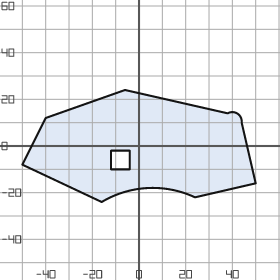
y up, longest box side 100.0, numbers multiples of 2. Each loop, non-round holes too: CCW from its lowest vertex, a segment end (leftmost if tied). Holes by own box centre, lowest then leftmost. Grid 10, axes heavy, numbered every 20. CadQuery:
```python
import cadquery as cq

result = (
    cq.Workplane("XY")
    .moveTo(-16.0, -24.0)
    .threePointArc((4.0, -18.0), (24.0, -22.0))
    .lineTo(50.0, -16.0)
    .lineTo(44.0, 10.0)
    .threePointArc((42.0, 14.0), (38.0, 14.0))
    .lineTo(-6.0, 24.0)
    .lineTo(-40.0, 12.0)
    .lineTo(-50.0, -8.0)
    .close()
    .moveTo(-12.0, -10.0)
    .lineTo(-4.0, -10.0)
    .lineTo(-4.0, -2.0)
    .lineTo(-12.0, -2.0)
    .close()
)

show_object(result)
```